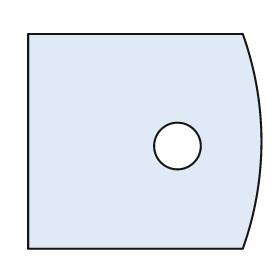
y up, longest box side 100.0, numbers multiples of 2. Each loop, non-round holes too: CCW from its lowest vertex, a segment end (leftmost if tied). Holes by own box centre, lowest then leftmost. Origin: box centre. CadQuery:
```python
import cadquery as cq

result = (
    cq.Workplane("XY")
    .moveTo(-50.0, -46.0)
    .lineTo(42.0, -46.0)
    .threePointArc((50.0, 0.0), (42.0, 46.0))
    .lineTo(-50.0, 46.0)
    .close()
    .moveTo(14.0, -2.0)
    .circle(10.0)
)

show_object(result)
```